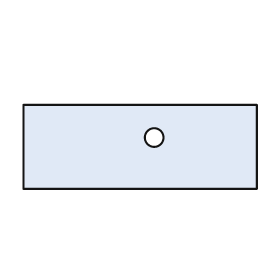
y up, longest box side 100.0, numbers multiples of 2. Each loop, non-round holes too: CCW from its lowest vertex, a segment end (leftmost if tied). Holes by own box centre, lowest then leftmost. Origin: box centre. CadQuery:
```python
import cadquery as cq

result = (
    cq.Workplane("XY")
    .moveTo(-50.0, -18.0)
    .lineTo(50.0, -18.0)
    .lineTo(50.0, 18.0)
    .lineTo(-50.0, 18.0)
    .close()
    .moveTo(6.0, 4.0)
    .circle(4.0)
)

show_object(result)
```